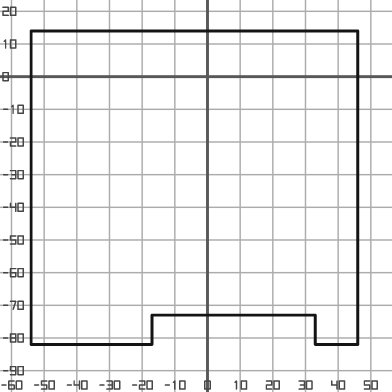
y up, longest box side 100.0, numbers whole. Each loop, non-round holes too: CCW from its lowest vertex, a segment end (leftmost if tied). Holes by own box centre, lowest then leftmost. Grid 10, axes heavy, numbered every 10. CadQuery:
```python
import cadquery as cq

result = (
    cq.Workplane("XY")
    .moveTo(-54.0, -82.0)
    .lineTo(-17.0, -82.0)
    .lineTo(-17.0, -73.0)
    .lineTo(33.0, -73.0)
    .lineTo(33.0, -82.0)
    .lineTo(46.0, -82.0)
    .lineTo(46.0, 14.0)
    .lineTo(-54.0, 14.0)
    .close()
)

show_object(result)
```